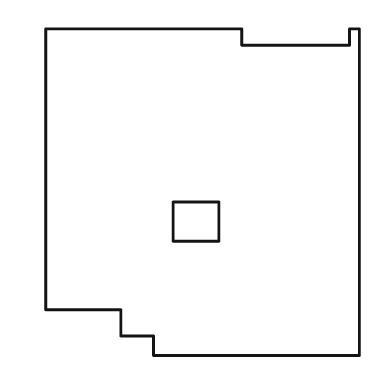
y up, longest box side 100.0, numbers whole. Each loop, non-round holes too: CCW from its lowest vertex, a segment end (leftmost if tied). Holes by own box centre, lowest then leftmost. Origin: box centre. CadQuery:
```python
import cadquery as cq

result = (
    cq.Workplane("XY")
    .moveTo(-15.0, -50.0)
    .lineTo(48.0, -50.0)
    .lineTo(48.0, 50.0)
    .lineTo(45.0, 50.0)
    .lineTo(45.0, 45.0)
    .lineTo(12.0, 45.0)
    .lineTo(12.0, 50.0)
    .lineTo(-48.0, 50.0)
    .lineTo(-48.0, -36.0)
    .lineTo(-25.0, -36.0)
    .lineTo(-25.0, -44.0)
    .lineTo(-15.0, -44.0)
    .close()
    .moveTo(-9.0, -15.0)
    .lineTo(5.0, -15.0)
    .lineTo(5.0, -3.0)
    .lineTo(-9.0, -3.0)
    .close()
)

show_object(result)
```